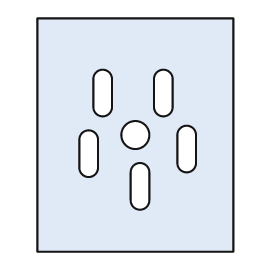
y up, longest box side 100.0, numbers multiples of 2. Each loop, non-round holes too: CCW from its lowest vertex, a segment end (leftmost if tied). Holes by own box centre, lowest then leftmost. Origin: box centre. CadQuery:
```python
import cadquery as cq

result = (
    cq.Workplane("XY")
    .moveTo(-42.0, -50.0)
    .lineTo(42.0, -50.0)
    .lineTo(42.0, 50.0)
    .lineTo(-42.0, 50.0)
    .close()
    .moveTo(-2.0, -28.0)
    .threePointArc((2.0, -32.0), (6.0, -28.0))
    .lineTo(6.0, -16.0)
    .threePointArc((2.0, -12.0), (-2.0, -16.0))
    .close()
    .moveTo(-24.0, -14.0)
    .threePointArc((-20.0, -18.0), (-16.0, -14.0))
    .lineTo(-16.0, -2.0)
    .threePointArc((-20.0, 2.0), (-24.0, -2.0))
    .close()
    .moveTo(18.0, -12.0)
    .threePointArc((22.0, -16.0), (26.0, -12.0))
    .lineTo(26.0, 0.0)
    .threePointArc((22.0, 4.0), (18.0, 0.0))
    .close()
    .moveTo(0.0, 0.0)
    .circle(6.0)
    .moveTo(-18.0, 12.0)
    .threePointArc((-14.0, 8.0), (-10.0, 12.0))
    .lineTo(-10.0, 24.0)
    .threePointArc((-14.0, 28.0), (-18.0, 24.0))
    .close()
    .moveTo(8.0, 12.0)
    .threePointArc((12.0, 8.0), (16.0, 12.0))
    .lineTo(16.0, 24.0)
    .threePointArc((12.0, 28.0), (8.0, 24.0))
    .close()
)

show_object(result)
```